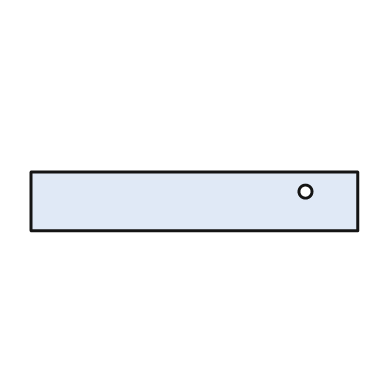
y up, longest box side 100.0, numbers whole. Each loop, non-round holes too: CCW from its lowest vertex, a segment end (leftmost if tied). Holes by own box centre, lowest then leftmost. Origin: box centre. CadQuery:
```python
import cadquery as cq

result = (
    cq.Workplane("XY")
    .moveTo(-50.0, -9.0)
    .lineTo(50.0, -9.0)
    .lineTo(50.0, 9.0)
    .lineTo(-50.0, 9.0)
    .close()
    .moveTo(34.0, 3.0)
    .circle(2.0)
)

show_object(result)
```